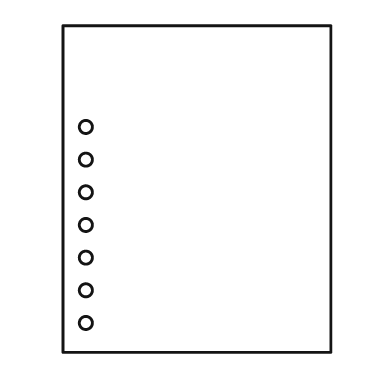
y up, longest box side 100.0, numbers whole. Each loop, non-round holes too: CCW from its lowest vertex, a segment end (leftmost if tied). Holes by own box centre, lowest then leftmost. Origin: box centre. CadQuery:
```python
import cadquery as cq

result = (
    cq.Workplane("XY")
    .moveTo(-41.0, -50.0)
    .lineTo(41.0, -50.0)
    .lineTo(41.0, 50.0)
    .lineTo(-41.0, 50.0)
    .close()
    .moveTo(-34.0, -41.0)
    .circle(2.0)
    .moveTo(-34.0, -31.0)
    .circle(2.0)
    .moveTo(-34.0, -21.0)
    .circle(2.0)
    .moveTo(-34.0, -11.0)
    .circle(2.0)
    .moveTo(-34.0, -1.0)
    .circle(2.0)
    .moveTo(-34.0, 9.0)
    .circle(2.0)
    .moveTo(-34.0, 19.0)
    .circle(2.0)
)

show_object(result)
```